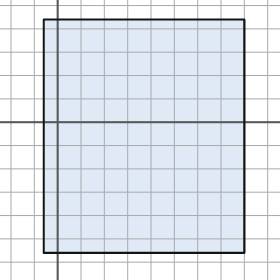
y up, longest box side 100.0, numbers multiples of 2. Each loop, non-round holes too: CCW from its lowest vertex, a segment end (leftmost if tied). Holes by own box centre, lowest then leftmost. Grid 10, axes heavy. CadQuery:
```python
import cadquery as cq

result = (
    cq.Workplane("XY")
    .moveTo(-6.0, -56.0)
    .lineTo(80.0, -56.0)
    .lineTo(80.0, 44.0)
    .lineTo(-6.0, 44.0)
    .close()
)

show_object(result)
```